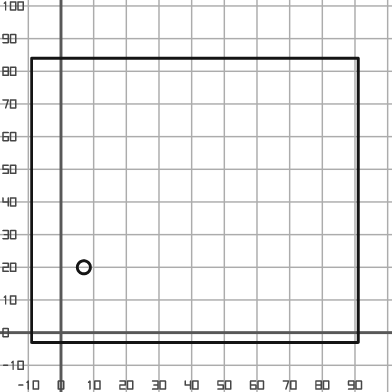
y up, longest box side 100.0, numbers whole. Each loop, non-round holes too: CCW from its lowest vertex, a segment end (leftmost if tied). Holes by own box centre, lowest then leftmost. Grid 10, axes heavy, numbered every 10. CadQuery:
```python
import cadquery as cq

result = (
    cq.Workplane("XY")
    .moveTo(-9.0, -3.0)
    .lineTo(91.0, -3.0)
    .lineTo(91.0, 84.0)
    .lineTo(-9.0, 84.0)
    .close()
    .moveTo(7.0, 20.0)
    .circle(2.0)
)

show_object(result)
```